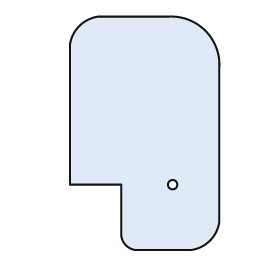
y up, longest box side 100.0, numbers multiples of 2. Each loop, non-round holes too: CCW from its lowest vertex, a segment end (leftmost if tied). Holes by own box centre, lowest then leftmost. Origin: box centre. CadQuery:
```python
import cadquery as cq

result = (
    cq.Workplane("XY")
    .moveTo(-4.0, -50.0)
    .lineTo(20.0, -50.0)
    .threePointArc((28.0, -46.0), (32.0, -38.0))
    .lineTo(32.0, 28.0)
    .threePointArc((26.0, 44.0), (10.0, 50.0))
    .lineTo(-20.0, 50.0)
    .threePointArc((-28.0, 46.0), (-32.0, 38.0))
    .lineTo(-32.0, -22.0)
    .lineTo(-10.0, -22.0)
    .lineTo(-10.0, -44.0)
    .threePointArc((-8.0, -48.0), (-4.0, -50.0))
    .close()
    .moveTo(12.0, -22.0)
    .circle(2.0)
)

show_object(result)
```